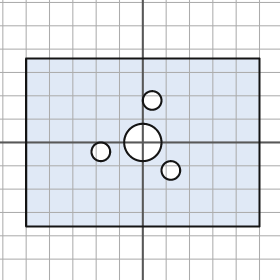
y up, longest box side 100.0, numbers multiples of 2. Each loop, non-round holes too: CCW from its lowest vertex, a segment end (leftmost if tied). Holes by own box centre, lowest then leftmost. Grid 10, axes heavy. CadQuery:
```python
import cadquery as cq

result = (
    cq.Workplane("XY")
    .moveTo(-50.0, -36.0)
    .lineTo(50.0, -36.0)
    .lineTo(50.0, 36.0)
    .lineTo(-50.0, 36.0)
    .close()
    .moveTo(12.0, -12.0)
    .circle(4.0)
    .moveTo(-18.0, -4.0)
    .circle(4.0)
    .moveTo(0.0, 0.0)
    .circle(8.0)
    .moveTo(4.0, 18.0)
    .circle(4.0)
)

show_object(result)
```